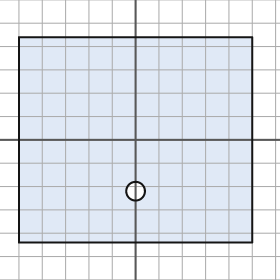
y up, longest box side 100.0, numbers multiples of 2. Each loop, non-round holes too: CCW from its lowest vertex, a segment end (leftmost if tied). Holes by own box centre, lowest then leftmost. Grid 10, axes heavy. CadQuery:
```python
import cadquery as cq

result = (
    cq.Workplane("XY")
    .moveTo(-50.0, -44.0)
    .lineTo(50.0, -44.0)
    .lineTo(50.0, 44.0)
    .lineTo(-50.0, 44.0)
    .close()
    .moveTo(0.0, -22.0)
    .circle(4.0)
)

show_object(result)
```